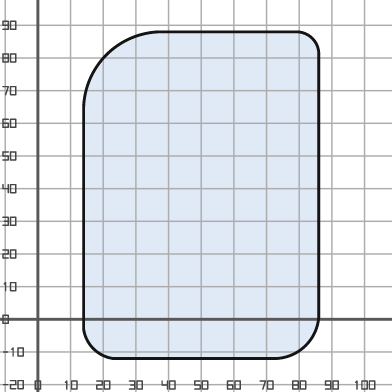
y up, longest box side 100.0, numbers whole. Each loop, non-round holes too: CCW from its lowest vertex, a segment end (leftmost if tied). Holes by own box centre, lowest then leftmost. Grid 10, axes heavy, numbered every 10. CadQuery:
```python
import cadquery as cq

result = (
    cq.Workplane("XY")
    .moveTo(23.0, -12.0)
    .lineTo(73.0, -12.0)
    .threePointArc((82.0, -8.0), (86.0, 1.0))
    .lineTo(86.0, 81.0)
    .threePointArc((84.0, 86.0), (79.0, 88.0))
    .lineTo(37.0, 88.0)
    .threePointArc((21.0, 81.0), (14.0, 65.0))
    .lineTo(14.0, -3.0)
    .threePointArc((17.0, -9.0), (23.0, -12.0))
    .close()
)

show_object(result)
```